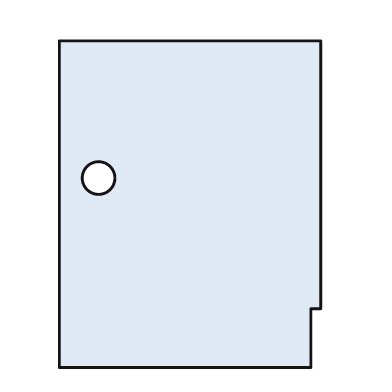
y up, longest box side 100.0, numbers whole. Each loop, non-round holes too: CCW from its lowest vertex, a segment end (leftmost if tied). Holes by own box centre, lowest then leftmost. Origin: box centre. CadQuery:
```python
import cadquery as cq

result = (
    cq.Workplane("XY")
    .moveTo(-40.0, -50.0)
    .lineTo(37.0, -50.0)
    .lineTo(37.0, -32.0)
    .lineTo(40.0, -32.0)
    .lineTo(40.0, 50.0)
    .lineTo(-40.0, 50.0)
    .close()
    .moveTo(-28.0, 8.0)
    .circle(5.0)
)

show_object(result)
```